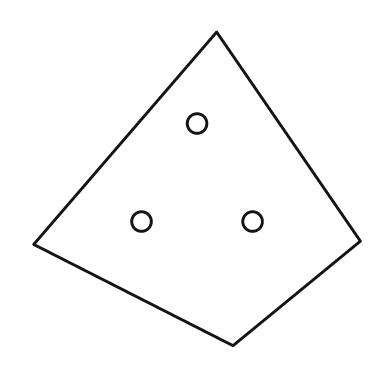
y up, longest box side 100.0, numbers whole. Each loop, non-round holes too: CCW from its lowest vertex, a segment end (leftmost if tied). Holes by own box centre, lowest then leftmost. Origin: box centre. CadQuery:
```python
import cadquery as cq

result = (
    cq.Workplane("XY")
    .moveTo(11.0, -48.0)
    .lineTo(50.0, -16.0)
    .lineTo(6.0, 48.0)
    .lineTo(-50.0, -17.0)
    .close()
    .moveTo(-17.0, -10.0)
    .circle(3.0)
    .moveTo(17.0, -10.0)
    .circle(3.0)
    .moveTo(0.0, 20.0)
    .circle(3.0)
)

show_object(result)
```